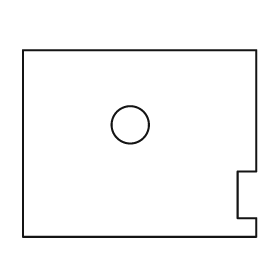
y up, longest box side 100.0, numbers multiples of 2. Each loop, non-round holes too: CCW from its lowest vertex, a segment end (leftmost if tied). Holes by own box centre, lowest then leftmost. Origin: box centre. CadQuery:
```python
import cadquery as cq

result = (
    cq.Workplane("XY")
    .moveTo(-50.0, -40.0)
    .lineTo(50.0, -40.0)
    .lineTo(50.0, -32.0)
    .lineTo(42.0, -32.0)
    .lineTo(42.0, -12.0)
    .lineTo(50.0, -12.0)
    .lineTo(50.0, 40.0)
    .lineTo(-50.0, 40.0)
    .close()
    .moveTo(-4.0, 8.0)
    .circle(8.0)
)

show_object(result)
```